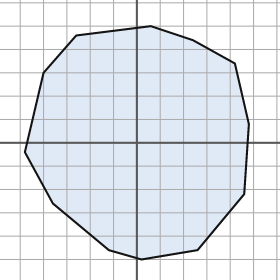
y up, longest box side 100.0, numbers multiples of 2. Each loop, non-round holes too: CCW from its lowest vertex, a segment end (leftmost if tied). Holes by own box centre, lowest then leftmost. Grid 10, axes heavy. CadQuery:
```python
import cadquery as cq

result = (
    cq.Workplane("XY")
    .moveTo(2.0, -50.0)
    .lineTo(26.0, -46.0)
    .lineTo(46.0, -22.0)
    .lineTo(48.0, 8.0)
    .lineTo(42.0, 34.0)
    .lineTo(24.0, 44.0)
    .lineTo(6.0, 50.0)
    .lineTo(-26.0, 46.0)
    .lineTo(-40.0, 30.0)
    .lineTo(-48.0, -4.0)
    .lineTo(-36.0, -26.0)
    .lineTo(-12.0, -46.0)
    .close()
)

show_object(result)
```